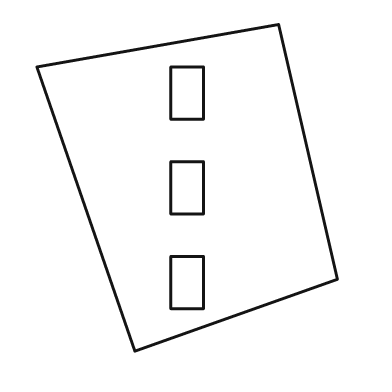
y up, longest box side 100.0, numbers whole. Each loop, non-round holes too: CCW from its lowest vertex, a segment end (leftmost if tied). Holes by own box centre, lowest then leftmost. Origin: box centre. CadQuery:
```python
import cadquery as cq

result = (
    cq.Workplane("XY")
    .moveTo(-16.0, -50.0)
    .lineTo(46.0, -28.0)
    .lineTo(28.0, 50.0)
    .lineTo(-46.0, 37.0)
    .close()
    .moveTo(-5.0, -37.0)
    .lineTo(5.0, -37.0)
    .lineTo(5.0, -21.0)
    .lineTo(-5.0, -21.0)
    .close()
    .moveTo(-5.0, -8.0)
    .lineTo(5.0, -8.0)
    .lineTo(5.0, 8.0)
    .lineTo(-5.0, 8.0)
    .close()
    .moveTo(-5.0, 21.0)
    .lineTo(5.0, 21.0)
    .lineTo(5.0, 37.0)
    .lineTo(-5.0, 37.0)
    .close()
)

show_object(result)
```